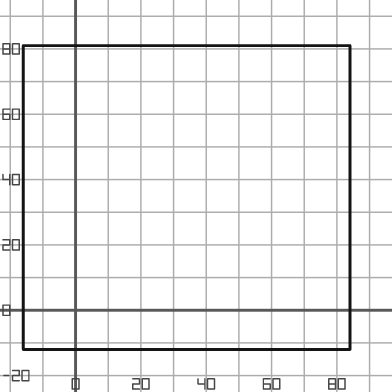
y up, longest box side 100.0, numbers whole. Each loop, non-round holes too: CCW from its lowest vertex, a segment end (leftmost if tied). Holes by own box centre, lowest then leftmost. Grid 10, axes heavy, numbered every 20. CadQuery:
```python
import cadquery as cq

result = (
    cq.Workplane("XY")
    .moveTo(-16.0, -12.0)
    .lineTo(84.0, -12.0)
    .lineTo(84.0, 81.0)
    .lineTo(-16.0, 81.0)
    .close()
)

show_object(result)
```